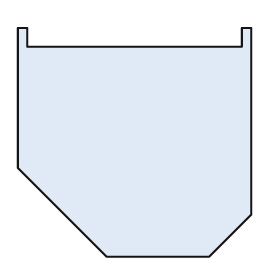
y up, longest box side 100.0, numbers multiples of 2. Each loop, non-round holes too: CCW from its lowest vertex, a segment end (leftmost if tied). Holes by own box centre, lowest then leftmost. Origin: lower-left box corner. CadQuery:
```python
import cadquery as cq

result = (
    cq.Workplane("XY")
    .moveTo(38.0, 0.0)
    .lineTo(82.0, 0.0)
    .lineTo(100.0, 18.0)
    .lineTo(100.0, 98.0)
    .lineTo(96.0, 98.0)
    .lineTo(96.0, 90.0)
    .lineTo(4.0, 90.0)
    .lineTo(4.0, 98.0)
    .lineTo(0.0, 98.0)
    .lineTo(0.0, 38.0)
    .close()
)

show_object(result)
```